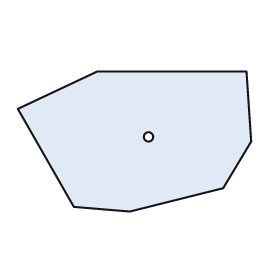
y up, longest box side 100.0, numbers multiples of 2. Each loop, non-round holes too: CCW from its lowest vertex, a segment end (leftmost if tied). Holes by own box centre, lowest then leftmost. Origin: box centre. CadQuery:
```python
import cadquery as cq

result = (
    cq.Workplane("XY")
    .moveTo(-2.0, -30.0)
    .lineTo(38.0, -20.0)
    .lineTo(50.0, 0.0)
    .lineTo(48.0, 30.0)
    .lineTo(-16.0, 30.0)
    .lineTo(-50.0, 14.0)
    .lineTo(-26.0, -28.0)
    .close()
    .moveTo(6.0, 2.0)
    .circle(2.0)
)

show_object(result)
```